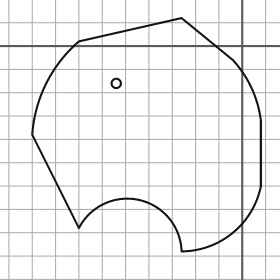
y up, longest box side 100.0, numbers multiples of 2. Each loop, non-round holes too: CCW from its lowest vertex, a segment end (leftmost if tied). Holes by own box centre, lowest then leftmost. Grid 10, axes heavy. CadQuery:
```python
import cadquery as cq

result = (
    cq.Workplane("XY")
    .moveTo(-26.0, -88.0)
    .threePointArc((-4.0, -80.0), (8.0, -60.0))
    .lineTo(8.0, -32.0)
    .threePointArc((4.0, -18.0), (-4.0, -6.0))
    .lineTo(-26.0, 12.0)
    .lineTo(-70.0, 2.0)
    .threePointArc((-84.0, -16.0), (-90.0, -38.0))
    .lineTo(-70.0, -78.0)
    .threePointArc((-44.0, -66.0), (-26.0, -88.0))
    .close()
    .moveTo(-54.0, -16.0)
    .circle(2.0)
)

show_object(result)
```